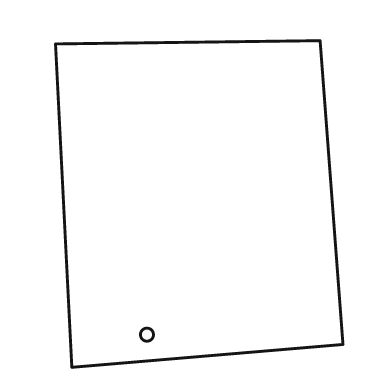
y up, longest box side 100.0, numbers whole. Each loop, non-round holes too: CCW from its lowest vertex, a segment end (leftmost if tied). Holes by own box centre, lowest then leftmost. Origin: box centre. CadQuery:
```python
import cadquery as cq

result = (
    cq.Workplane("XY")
    .moveTo(-39.0, -50.0)
    .lineTo(44.0, -43.0)
    .lineTo(37.0, 50.0)
    .lineTo(-44.0, 49.0)
    .close()
    .moveTo(-16.0, -40.0)
    .circle(2.0)
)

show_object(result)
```